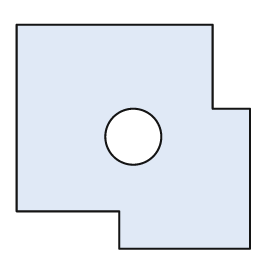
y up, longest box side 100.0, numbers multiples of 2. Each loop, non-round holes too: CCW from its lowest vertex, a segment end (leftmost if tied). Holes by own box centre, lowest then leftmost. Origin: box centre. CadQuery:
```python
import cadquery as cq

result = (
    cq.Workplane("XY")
    .moveTo(-6.0, -48.0)
    .lineTo(50.0, -48.0)
    .lineTo(50.0, 12.0)
    .lineTo(34.0, 12.0)
    .lineTo(34.0, 48.0)
    .lineTo(-50.0, 48.0)
    .lineTo(-50.0, -32.0)
    .lineTo(-6.0, -32.0)
    .close()
    .moveTo(0.0, 0.0)
    .circle(12.0)
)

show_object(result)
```